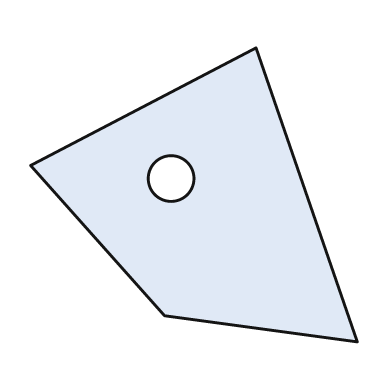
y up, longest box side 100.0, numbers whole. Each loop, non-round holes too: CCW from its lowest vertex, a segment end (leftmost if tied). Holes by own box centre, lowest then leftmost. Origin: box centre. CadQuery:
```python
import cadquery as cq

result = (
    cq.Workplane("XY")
    .moveTo(50.0, -45.0)
    .lineTo(19.0, 45.0)
    .lineTo(-50.0, 9.0)
    .lineTo(-9.0, -37.0)
    .close()
    .moveTo(-7.0, 5.0)
    .circle(7.0)
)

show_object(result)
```